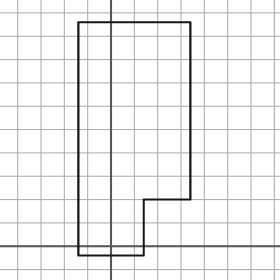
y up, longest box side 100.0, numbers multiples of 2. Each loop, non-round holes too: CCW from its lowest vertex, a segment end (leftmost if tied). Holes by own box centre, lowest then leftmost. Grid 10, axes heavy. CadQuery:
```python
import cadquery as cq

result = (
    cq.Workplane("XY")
    .moveTo(-14.0, -4.0)
    .lineTo(14.0, -4.0)
    .lineTo(14.0, 20.0)
    .lineTo(34.0, 20.0)
    .lineTo(34.0, 96.0)
    .lineTo(-14.0, 96.0)
    .close()
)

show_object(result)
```